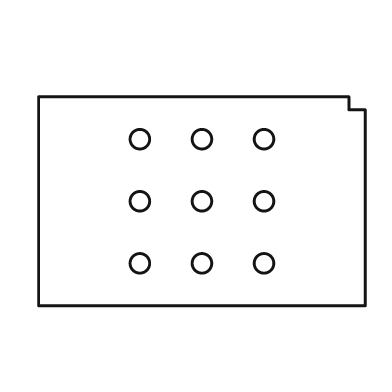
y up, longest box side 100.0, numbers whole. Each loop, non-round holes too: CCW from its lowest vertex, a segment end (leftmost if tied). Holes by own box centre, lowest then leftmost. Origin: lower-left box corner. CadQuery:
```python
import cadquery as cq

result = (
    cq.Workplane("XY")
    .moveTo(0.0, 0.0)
    .lineTo(100.0, 0.0)
    .lineTo(100.0, 60.0)
    .lineTo(95.0, 60.0)
    .lineTo(95.0, 64.0)
    .lineTo(0.0, 64.0)
    .close()
    .moveTo(31.0, 13.0)
    .circle(3.0)
    .moveTo(50.0, 13.0)
    .circle(3.0)
    .moveTo(69.0, 13.0)
    .circle(3.0)
    .moveTo(31.0, 32.0)
    .circle(3.0)
    .moveTo(50.0, 32.0)
    .circle(3.0)
    .moveTo(69.0, 32.0)
    .circle(3.0)
    .moveTo(31.0, 51.0)
    .circle(3.0)
    .moveTo(50.0, 51.0)
    .circle(3.0)
    .moveTo(69.0, 51.0)
    .circle(3.0)
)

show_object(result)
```